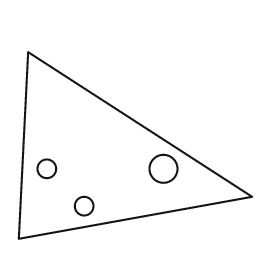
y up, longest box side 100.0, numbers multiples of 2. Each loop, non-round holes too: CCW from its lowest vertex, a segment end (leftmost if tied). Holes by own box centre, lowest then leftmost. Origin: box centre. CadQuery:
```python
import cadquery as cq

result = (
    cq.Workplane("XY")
    .moveTo(-50.0, -40.0)
    .lineTo(50.0, -22.0)
    .lineTo(-46.0, 40.0)
    .close()
    .moveTo(-22.0, -26.0)
    .circle(4.0)
    .moveTo(-38.0, -10.0)
    .circle(4.0)
    .moveTo(12.0, -10.0)
    .circle(6.0)
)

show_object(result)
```